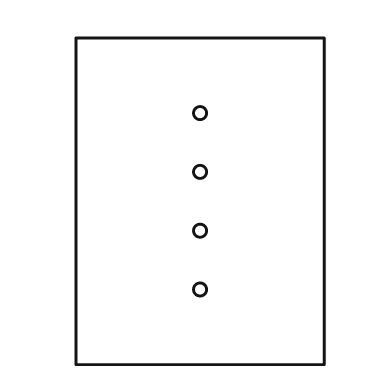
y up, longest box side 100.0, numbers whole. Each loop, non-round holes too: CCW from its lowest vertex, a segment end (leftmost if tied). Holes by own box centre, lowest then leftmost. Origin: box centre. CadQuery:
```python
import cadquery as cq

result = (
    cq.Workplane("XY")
    .moveTo(-38.0, -50.0)
    .lineTo(38.0, -50.0)
    .lineTo(38.0, 50.0)
    .lineTo(-38.0, 50.0)
    .close()
    .moveTo(0.0, -27.0)
    .circle(2.0)
    .moveTo(0.0, -9.0)
    .circle(2.0)
    .moveTo(0.0, 9.0)
    .circle(2.0)
    .moveTo(0.0, 27.0)
    .circle(2.0)
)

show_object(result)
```